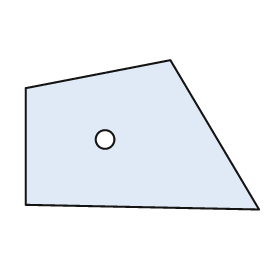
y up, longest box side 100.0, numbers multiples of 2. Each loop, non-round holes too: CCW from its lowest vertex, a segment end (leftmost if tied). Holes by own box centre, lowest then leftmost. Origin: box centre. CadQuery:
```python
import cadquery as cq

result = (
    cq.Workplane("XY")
    .moveTo(50.0, -32.0)
    .lineTo(12.0, 32.0)
    .lineTo(-50.0, 20.0)
    .lineTo(-50.0, -30.0)
    .close()
    .moveTo(-16.0, -2.0)
    .circle(4.0)
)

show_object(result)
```